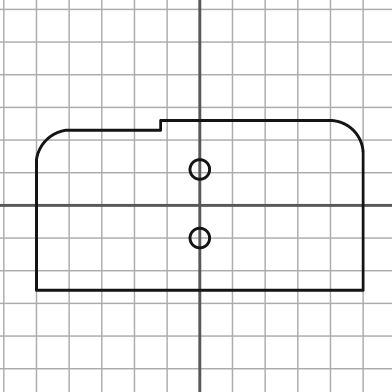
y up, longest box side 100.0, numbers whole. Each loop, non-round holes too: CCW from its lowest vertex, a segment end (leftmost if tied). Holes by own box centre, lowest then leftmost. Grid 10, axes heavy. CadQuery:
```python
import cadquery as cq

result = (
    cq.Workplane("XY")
    .moveTo(-50.0, -26.0)
    .lineTo(50.0, -26.0)
    .lineTo(50.0, 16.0)
    .threePointArc((47.0, 23.0), (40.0, 26.0))
    .lineTo(-12.0, 26.0)
    .lineTo(-12.0, 23.0)
    .lineTo(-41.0, 23.0)
    .threePointArc((-47.0, 20.0), (-50.0, 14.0))
    .close()
    .moveTo(0.0, -10.0)
    .circle(3.0)
    .moveTo(0.0, 11.0)
    .circle(3.0)
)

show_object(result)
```